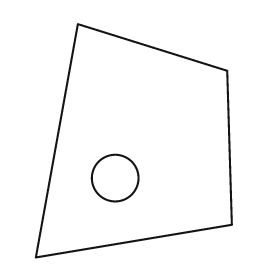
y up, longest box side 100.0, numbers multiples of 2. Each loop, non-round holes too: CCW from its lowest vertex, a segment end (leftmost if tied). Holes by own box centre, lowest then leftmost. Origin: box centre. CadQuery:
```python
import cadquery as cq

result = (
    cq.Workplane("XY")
    .moveTo(-42.0, -50.0)
    .lineTo(42.0, -36.0)
    .lineTo(40.0, 30.0)
    .lineTo(-24.0, 50.0)
    .close()
    .moveTo(-8.0, -16.0)
    .circle(10.0)
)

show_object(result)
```